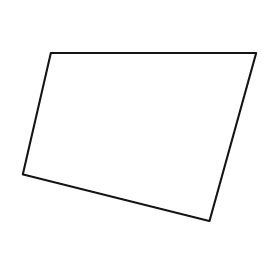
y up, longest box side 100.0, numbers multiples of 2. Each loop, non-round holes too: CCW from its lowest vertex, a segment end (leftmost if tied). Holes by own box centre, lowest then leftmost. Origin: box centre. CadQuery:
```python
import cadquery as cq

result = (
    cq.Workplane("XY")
    .moveTo(30.0, -36.0)
    .lineTo(50.0, 36.0)
    .lineTo(-38.0, 36.0)
    .lineTo(-50.0, -16.0)
    .close()
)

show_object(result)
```